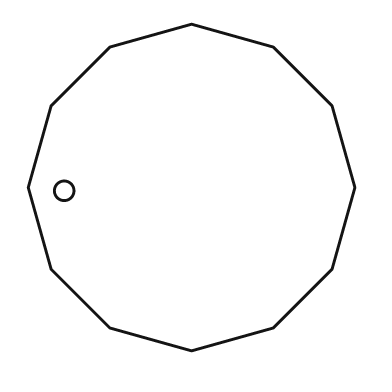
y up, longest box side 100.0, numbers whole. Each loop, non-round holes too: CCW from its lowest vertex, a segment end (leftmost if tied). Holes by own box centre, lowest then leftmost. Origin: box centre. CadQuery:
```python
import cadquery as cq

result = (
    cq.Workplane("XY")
    .moveTo(0.0, -50.0)
    .lineTo(25.0, -43.0)
    .lineTo(43.0, -25.0)
    .lineTo(50.0, 0.0)
    .lineTo(43.0, 25.0)
    .lineTo(25.0, 43.0)
    .lineTo(0.0, 50.0)
    .lineTo(-25.0, 43.0)
    .lineTo(-43.0, 25.0)
    .lineTo(-50.0, 0.0)
    .lineTo(-43.0, -25.0)
    .lineTo(-25.0, -43.0)
    .close()
    .moveTo(-39.0, -1.0)
    .circle(3.0)
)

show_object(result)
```